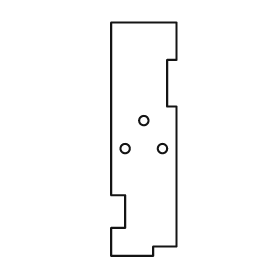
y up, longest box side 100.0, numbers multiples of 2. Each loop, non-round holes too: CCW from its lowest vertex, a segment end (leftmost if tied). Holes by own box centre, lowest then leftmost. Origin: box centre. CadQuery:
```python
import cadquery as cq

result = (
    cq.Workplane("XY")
    .moveTo(-14.0, -50.0)
    .lineTo(4.0, -50.0)
    .lineTo(4.0, -46.0)
    .lineTo(14.0, -46.0)
    .lineTo(14.0, 14.0)
    .lineTo(10.0, 14.0)
    .lineTo(10.0, 34.0)
    .lineTo(14.0, 34.0)
    .lineTo(14.0, 50.0)
    .lineTo(-14.0, 50.0)
    .lineTo(-14.0, -24.0)
    .lineTo(-8.0, -24.0)
    .lineTo(-8.0, -38.0)
    .lineTo(-14.0, -38.0)
    .close()
    .moveTo(-8.0, -4.0)
    .circle(2.0)
    .moveTo(8.0, -4.0)
    .circle(2.0)
    .moveTo(0.0, 8.0)
    .circle(2.0)
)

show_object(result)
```